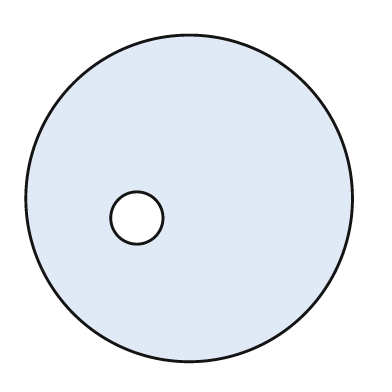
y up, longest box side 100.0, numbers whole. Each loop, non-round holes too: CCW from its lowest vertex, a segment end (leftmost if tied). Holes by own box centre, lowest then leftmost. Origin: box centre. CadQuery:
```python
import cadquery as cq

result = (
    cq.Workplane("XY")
    .moveTo(0.0, 0.0)
    .circle(50.0)
    .moveTo(-16.0, -6.0)
    .circle(8.0)
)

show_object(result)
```